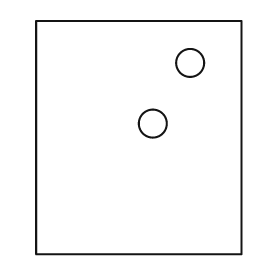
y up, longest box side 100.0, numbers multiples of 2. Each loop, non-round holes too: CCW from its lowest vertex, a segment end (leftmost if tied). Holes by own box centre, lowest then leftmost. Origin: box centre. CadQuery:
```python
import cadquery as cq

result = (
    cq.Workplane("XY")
    .moveTo(-44.0, -50.0)
    .lineTo(44.0, -50.0)
    .lineTo(44.0, 50.0)
    .lineTo(-44.0, 50.0)
    .close()
    .moveTo(6.0, 6.0)
    .circle(6.0)
    .moveTo(22.0, 32.0)
    .circle(6.0)
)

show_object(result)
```